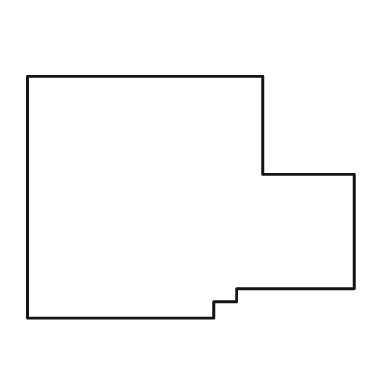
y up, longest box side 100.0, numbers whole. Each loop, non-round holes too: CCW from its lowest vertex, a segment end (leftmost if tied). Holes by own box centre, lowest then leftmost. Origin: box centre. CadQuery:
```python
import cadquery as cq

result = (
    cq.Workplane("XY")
    .moveTo(-50.0, -37.0)
    .lineTo(7.0, -37.0)
    .lineTo(7.0, -32.0)
    .lineTo(14.0, -32.0)
    .lineTo(14.0, -28.0)
    .lineTo(50.0, -28.0)
    .lineTo(50.0, 7.0)
    .lineTo(22.0, 7.0)
    .lineTo(22.0, 37.0)
    .lineTo(-50.0, 37.0)
    .close()
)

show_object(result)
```